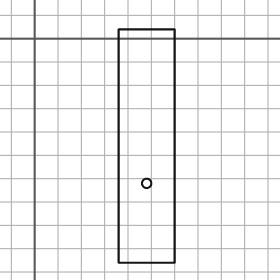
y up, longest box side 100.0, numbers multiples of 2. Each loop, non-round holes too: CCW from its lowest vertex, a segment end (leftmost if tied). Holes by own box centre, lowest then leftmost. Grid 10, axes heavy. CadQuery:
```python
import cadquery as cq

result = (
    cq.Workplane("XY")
    .moveTo(36.0, -96.0)
    .lineTo(60.0, -96.0)
    .lineTo(60.0, 4.0)
    .lineTo(36.0, 4.0)
    .close()
    .moveTo(48.0, -62.0)
    .circle(2.0)
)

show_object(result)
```